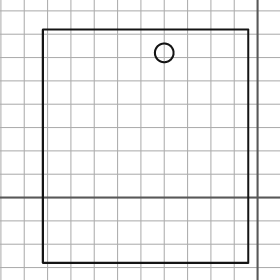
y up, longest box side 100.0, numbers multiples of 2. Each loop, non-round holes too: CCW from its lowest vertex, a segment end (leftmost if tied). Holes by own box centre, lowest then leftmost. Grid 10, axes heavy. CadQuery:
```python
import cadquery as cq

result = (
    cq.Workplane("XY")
    .moveTo(-92.0, -28.0)
    .lineTo(-4.0, -28.0)
    .lineTo(-4.0, 72.0)
    .lineTo(-92.0, 72.0)
    .close()
    .moveTo(-40.0, 62.0)
    .circle(4.0)
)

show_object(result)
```